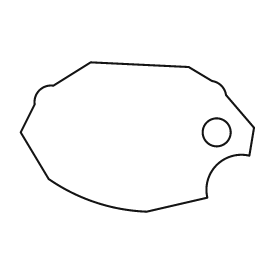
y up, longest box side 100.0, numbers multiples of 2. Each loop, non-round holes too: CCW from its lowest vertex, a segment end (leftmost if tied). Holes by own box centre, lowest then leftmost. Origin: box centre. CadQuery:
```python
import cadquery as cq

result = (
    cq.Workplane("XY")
    .moveTo(4.0, -32.0)
    .lineTo(30.0, -26.0)
    .threePointArc((34.0, -12.0), (48.0, -8.0))
    .lineTo(50.0, 4.0)
    .lineTo(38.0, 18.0)
    .threePointArc((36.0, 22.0), (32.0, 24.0))
    .lineTo(22.0, 30.0)
    .lineTo(-20.0, 32.0)
    .lineTo(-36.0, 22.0)
    .threePointArc((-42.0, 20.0), (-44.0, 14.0))
    .lineTo(-50.0, 2.0)
    .lineTo(-38.0, -18.0)
    .threePointArc((-18.0, -28.0), (4.0, -32.0))
    .close()
    .moveTo(34.0, 2.0)
    .circle(6.0)
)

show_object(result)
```